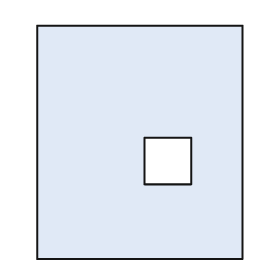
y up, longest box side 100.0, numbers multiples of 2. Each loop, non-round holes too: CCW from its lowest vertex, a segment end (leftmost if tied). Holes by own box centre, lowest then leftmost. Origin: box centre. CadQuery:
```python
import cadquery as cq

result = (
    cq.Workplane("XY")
    .moveTo(-44.0, -50.0)
    .lineTo(44.0, -50.0)
    .lineTo(44.0, 50.0)
    .lineTo(-44.0, 50.0)
    .close()
    .moveTo(2.0, -18.0)
    .lineTo(22.0, -18.0)
    .lineTo(22.0, 2.0)
    .lineTo(2.0, 2.0)
    .close()
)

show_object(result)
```